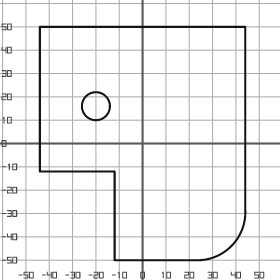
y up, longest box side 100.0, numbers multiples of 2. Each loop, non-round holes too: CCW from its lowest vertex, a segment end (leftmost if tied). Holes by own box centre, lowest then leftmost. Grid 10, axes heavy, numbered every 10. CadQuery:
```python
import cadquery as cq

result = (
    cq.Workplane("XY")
    .moveTo(-12.0, -50.0)
    .lineTo(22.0, -50.0)
    .threePointArc((38.0, -44.0), (44.0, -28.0))
    .lineTo(44.0, 50.0)
    .lineTo(-44.0, 50.0)
    .lineTo(-44.0, -12.0)
    .lineTo(-12.0, -12.0)
    .close()
    .moveTo(-20.0, 16.0)
    .circle(6.0)
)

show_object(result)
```